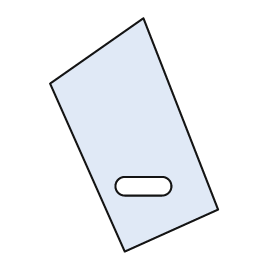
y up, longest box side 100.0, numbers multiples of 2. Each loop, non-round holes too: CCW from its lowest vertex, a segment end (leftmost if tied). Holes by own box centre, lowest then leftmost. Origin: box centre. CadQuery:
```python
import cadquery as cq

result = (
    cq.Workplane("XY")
    .moveTo(-4.0, -50.0)
    .lineTo(36.0, -32.0)
    .lineTo(4.0, 50.0)
    .lineTo(-36.0, 22.0)
    .close()
    .moveTo(-4.0, -26.0)
    .lineTo(12.0, -26.0)
    .threePointArc((16.0, -22.0), (12.0, -18.0))
    .lineTo(-4.0, -18.0)
    .threePointArc((-8.0, -22.0), (-4.0, -26.0))
    .close()
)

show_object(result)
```